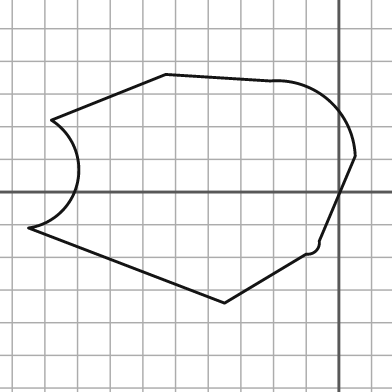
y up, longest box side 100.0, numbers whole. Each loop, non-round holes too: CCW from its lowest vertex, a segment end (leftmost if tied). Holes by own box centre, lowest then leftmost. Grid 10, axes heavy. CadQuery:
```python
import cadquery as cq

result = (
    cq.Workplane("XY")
    .moveTo(-35.0, -34.0)
    .lineTo(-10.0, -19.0)
    .threePointArc((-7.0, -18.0), (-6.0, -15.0))
    .lineTo(5.0, 11.0)
    .threePointArc((-3.0, 28.0), (-21.0, 34.0))
    .lineTo(-53.0, 36.0)
    .lineTo(-88.0, 22.0)
    .threePointArc((-80.0, 3.0), (-95.0, -11.0))
    .close()
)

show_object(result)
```